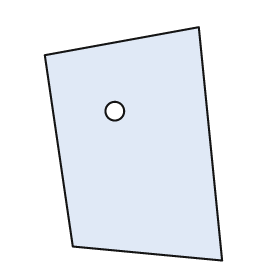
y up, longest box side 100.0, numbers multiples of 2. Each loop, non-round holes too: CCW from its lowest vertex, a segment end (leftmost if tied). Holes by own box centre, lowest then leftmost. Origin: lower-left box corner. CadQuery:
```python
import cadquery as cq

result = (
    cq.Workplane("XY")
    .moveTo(76.0, 0.0)
    .lineTo(66.0, 100.0)
    .lineTo(0.0, 88.0)
    .lineTo(12.0, 6.0)
    .close()
    .moveTo(30.0, 64.0)
    .circle(4.0)
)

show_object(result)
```